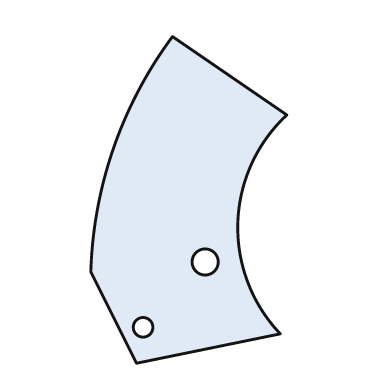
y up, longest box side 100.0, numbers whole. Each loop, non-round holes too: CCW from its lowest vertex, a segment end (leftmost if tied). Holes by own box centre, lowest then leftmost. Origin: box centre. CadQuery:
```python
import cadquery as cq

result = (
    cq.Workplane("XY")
    .moveTo(-16.0, -50.0)
    .lineTo(28.0, -41.0)
    .threePointArc((15.0, -7.0), (30.0, 26.0))
    .lineTo(-5.0, 50.0)
    .threePointArc((-23.0, 16.0), (-30.0, -22.0))
    .close()
    .moveTo(-14.0, -39.0)
    .circle(3.0)
    .moveTo(5.0, -19.0)
    .circle(4.0)
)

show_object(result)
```